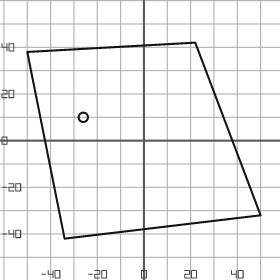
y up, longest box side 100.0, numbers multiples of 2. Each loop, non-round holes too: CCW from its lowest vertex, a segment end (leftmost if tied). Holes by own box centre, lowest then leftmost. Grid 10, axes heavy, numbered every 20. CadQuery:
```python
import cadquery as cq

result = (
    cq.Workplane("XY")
    .moveTo(-34.0, -42.0)
    .lineTo(50.0, -32.0)
    .lineTo(22.0, 42.0)
    .lineTo(-50.0, 38.0)
    .close()
    .moveTo(-26.0, 10.0)
    .circle(2.0)
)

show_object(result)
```